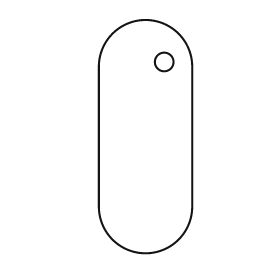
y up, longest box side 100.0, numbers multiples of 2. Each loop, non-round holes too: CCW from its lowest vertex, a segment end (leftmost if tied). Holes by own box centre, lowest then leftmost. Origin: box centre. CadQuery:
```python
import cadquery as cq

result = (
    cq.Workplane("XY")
    .moveTo(-20.0, -30.0)
    .threePointArc((0.0, -50.0), (20.0, -30.0))
    .lineTo(20.0, 30.0)
    .threePointArc((0.0, 50.0), (-20.0, 30.0))
    .close()
    .moveTo(8.0, 32.0)
    .circle(4.0)
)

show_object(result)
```